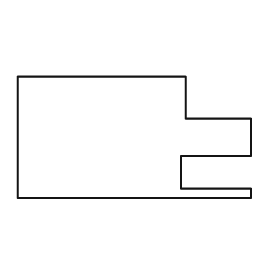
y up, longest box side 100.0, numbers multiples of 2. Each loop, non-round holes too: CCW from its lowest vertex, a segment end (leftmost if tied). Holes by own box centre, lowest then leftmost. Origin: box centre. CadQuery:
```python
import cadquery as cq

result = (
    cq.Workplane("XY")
    .moveTo(-50.0, -26.0)
    .lineTo(50.0, -26.0)
    .lineTo(50.0, -22.0)
    .lineTo(20.0, -22.0)
    .lineTo(20.0, -8.0)
    .lineTo(50.0, -8.0)
    .lineTo(50.0, 8.0)
    .lineTo(22.0, 8.0)
    .lineTo(22.0, 26.0)
    .lineTo(-50.0, 26.0)
    .close()
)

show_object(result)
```